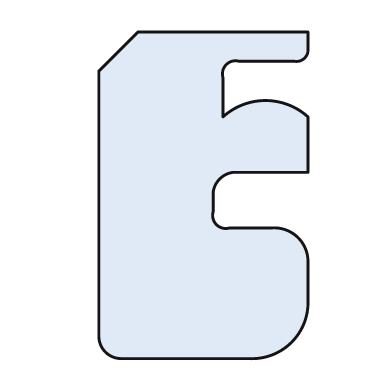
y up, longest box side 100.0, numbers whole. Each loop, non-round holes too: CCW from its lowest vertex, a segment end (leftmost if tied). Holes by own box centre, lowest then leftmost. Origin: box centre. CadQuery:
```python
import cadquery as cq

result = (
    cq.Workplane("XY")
    .moveTo(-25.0, -50.0)
    .lineTo(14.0, -50.0)
    .threePointArc((27.0, -45.0), (32.0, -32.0))
    .lineTo(32.0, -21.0)
    .threePointArc((29.0, -13.0), (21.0, -10.0))
    .lineTo(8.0, -10.0)
    .threePointArc((4.0, -9.0), (3.0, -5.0))
    .lineTo(3.0, 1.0)
    .threePointArc((5.0, 5.0), (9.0, 7.0))
    .lineTo(32.0, 7.0)
    .lineTo(32.0, 24.0)
    .threePointArc((19.0, 29.0), (6.0, 24.0))
    .lineTo(6.0, 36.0)
    .threePointArc((7.0, 40.0), (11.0, 41.0))
    .lineTo(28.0, 41.0)
    .threePointArc((31.0, 42.0), (32.0, 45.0))
    .lineTo(32.0, 50.0)
    .lineTo(-20.0, 50.0)
    .lineTo(-32.0, 38.0)
    .lineTo(-32.0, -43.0)
    .threePointArc((-30.0, -48.0), (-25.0, -50.0))
    .close()
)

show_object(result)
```